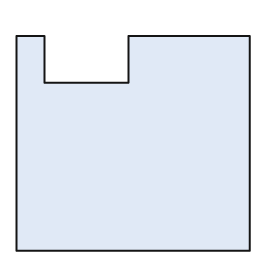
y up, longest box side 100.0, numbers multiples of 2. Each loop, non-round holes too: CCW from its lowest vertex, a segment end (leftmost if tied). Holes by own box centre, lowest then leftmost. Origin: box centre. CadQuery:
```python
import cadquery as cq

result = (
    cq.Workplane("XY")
    .moveTo(-50.0, -46.0)
    .lineTo(50.0, -46.0)
    .lineTo(50.0, 46.0)
    .lineTo(-2.0, 46.0)
    .lineTo(-2.0, 26.0)
    .lineTo(-38.0, 26.0)
    .lineTo(-38.0, 46.0)
    .lineTo(-50.0, 46.0)
    .close()
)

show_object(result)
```